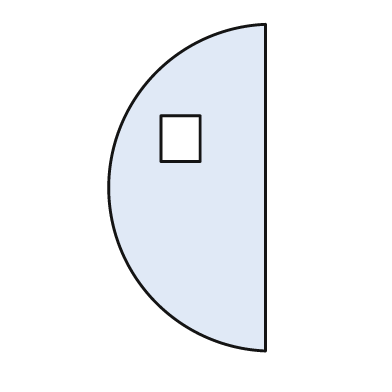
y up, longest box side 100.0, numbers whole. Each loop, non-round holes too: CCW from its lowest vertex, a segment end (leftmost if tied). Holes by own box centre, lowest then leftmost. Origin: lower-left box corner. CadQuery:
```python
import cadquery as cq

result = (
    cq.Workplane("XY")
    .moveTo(48.0, 0.0)
    .lineTo(48.0, 100.0)
    .threePointArc((0.0, 50.0), (48.0, 0.0))
    .close()
    .moveTo(16.0, 58.0)
    .lineTo(28.0, 58.0)
    .lineTo(28.0, 72.0)
    .lineTo(16.0, 72.0)
    .close()
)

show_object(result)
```